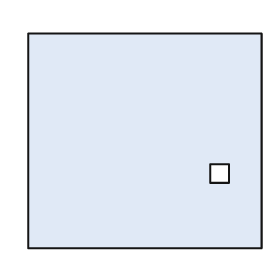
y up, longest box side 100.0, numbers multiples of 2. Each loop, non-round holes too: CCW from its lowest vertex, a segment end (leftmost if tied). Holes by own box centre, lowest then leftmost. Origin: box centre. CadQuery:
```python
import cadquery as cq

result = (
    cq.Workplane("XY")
    .moveTo(-50.0, -46.0)
    .lineTo(50.0, -46.0)
    .lineTo(50.0, 46.0)
    .lineTo(-50.0, 46.0)
    .close()
    .moveTo(28.0, -18.0)
    .lineTo(36.0, -18.0)
    .lineTo(36.0, -10.0)
    .lineTo(28.0, -10.0)
    .close()
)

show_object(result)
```